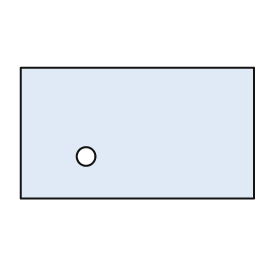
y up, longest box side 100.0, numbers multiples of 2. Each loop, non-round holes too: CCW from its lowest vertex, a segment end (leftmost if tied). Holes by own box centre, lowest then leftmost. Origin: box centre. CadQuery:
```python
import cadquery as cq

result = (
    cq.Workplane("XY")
    .moveTo(-50.0, -28.0)
    .lineTo(50.0, -28.0)
    .lineTo(50.0, 28.0)
    .lineTo(-50.0, 28.0)
    .close()
    .moveTo(-22.0, -10.0)
    .circle(4.0)
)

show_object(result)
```